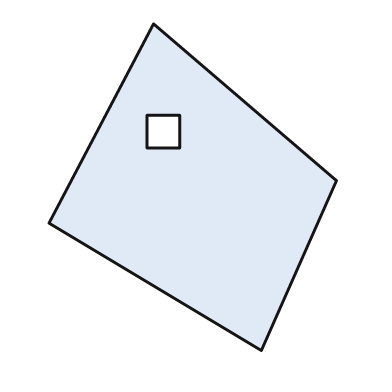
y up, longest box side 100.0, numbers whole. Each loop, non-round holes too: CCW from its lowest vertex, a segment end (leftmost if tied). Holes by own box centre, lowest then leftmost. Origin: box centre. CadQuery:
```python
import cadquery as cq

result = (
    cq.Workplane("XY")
    .moveTo(21.0, -50.0)
    .lineTo(44.0, 2.0)
    .lineTo(-12.0, 50.0)
    .lineTo(-44.0, -11.0)
    .close()
    .moveTo(-14.0, 12.0)
    .lineTo(-4.0, 12.0)
    .lineTo(-4.0, 22.0)
    .lineTo(-14.0, 22.0)
    .close()
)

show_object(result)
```